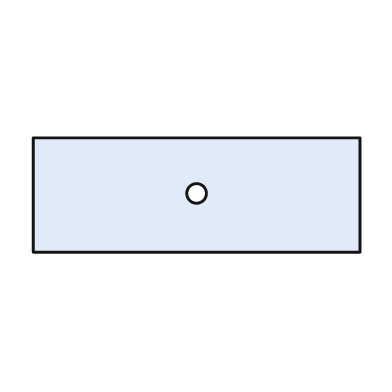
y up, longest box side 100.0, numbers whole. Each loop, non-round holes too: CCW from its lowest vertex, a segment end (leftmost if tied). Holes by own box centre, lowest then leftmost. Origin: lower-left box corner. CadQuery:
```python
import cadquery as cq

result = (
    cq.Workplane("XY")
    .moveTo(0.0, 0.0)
    .lineTo(100.0, 0.0)
    .lineTo(100.0, 35.0)
    .lineTo(0.0, 35.0)
    .close()
    .moveTo(50.0, 18.0)
    .circle(3.0)
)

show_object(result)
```